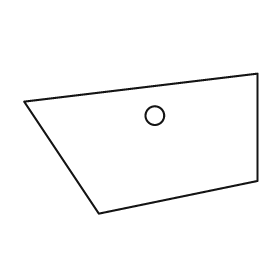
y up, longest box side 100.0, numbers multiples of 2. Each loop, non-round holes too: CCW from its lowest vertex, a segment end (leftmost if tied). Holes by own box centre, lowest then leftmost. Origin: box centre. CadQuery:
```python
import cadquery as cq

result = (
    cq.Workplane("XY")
    .moveTo(-18.0, -30.0)
    .lineTo(50.0, -16.0)
    .lineTo(50.0, 30.0)
    .lineTo(-50.0, 18.0)
    .close()
    .moveTo(6.0, 12.0)
    .circle(4.0)
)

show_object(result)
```